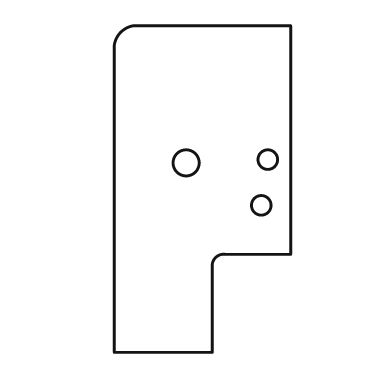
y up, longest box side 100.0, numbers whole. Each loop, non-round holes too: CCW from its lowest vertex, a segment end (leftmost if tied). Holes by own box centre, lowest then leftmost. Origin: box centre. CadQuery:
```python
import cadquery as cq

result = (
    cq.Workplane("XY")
    .moveTo(-27.0, -50.0)
    .lineTo(3.0, -50.0)
    .lineTo(3.0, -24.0)
    .threePointArc((4.0, -21.0), (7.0, -20.0))
    .lineTo(27.0, -20.0)
    .lineTo(27.0, 50.0)
    .lineTo(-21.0, 50.0)
    .threePointArc((-25.0, 48.0), (-27.0, 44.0))
    .close()
    .moveTo(18.0, -5.0)
    .circle(3.0)
    .moveTo(-5.0, 8.0)
    .circle(4.0)
    .moveTo(20.0, 9.0)
    .circle(3.0)
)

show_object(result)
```